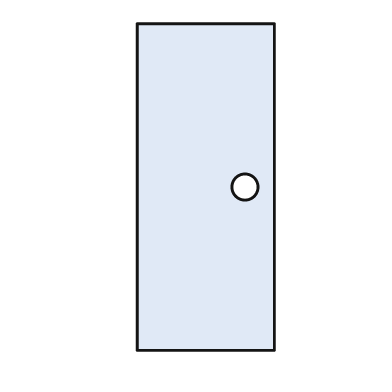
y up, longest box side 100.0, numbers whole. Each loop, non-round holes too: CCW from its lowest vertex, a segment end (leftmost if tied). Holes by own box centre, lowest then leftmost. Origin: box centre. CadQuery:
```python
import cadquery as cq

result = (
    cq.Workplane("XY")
    .moveTo(-21.0, -50.0)
    .lineTo(21.0, -50.0)
    .lineTo(21.0, 50.0)
    .lineTo(-21.0, 50.0)
    .close()
    .moveTo(12.0, 0.0)
    .circle(4.0)
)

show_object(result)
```